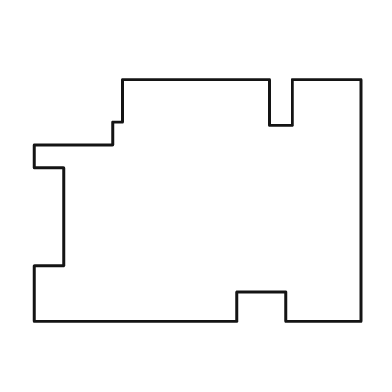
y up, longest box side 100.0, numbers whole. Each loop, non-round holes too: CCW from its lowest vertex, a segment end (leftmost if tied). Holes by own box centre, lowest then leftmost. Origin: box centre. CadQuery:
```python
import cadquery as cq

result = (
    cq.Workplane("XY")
    .moveTo(-50.0, -37.0)
    .lineTo(12.0, -37.0)
    .lineTo(12.0, -28.0)
    .lineTo(27.0, -28.0)
    .lineTo(27.0, -37.0)
    .lineTo(50.0, -37.0)
    .lineTo(50.0, 37.0)
    .lineTo(29.0, 37.0)
    .lineTo(29.0, 23.0)
    .lineTo(22.0, 23.0)
    .lineTo(22.0, 37.0)
    .lineTo(-23.0, 37.0)
    .lineTo(-23.0, 24.0)
    .lineTo(-26.0, 24.0)
    .lineTo(-26.0, 17.0)
    .lineTo(-50.0, 17.0)
    .lineTo(-50.0, 10.0)
    .lineTo(-41.0, 10.0)
    .lineTo(-41.0, -20.0)
    .lineTo(-50.0, -20.0)
    .close()
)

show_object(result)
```